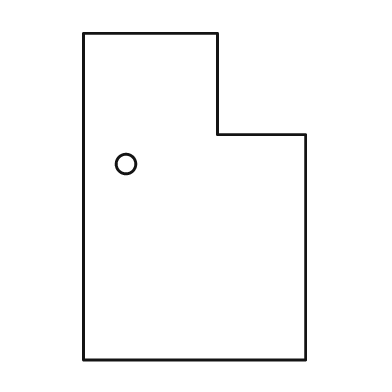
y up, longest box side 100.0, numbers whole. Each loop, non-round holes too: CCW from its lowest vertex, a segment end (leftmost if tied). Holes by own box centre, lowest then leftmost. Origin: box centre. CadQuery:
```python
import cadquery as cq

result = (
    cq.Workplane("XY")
    .moveTo(-34.0, -50.0)
    .lineTo(34.0, -50.0)
    .lineTo(34.0, 19.0)
    .lineTo(7.0, 19.0)
    .lineTo(7.0, 50.0)
    .lineTo(-34.0, 50.0)
    .close()
    .moveTo(-21.0, 10.0)
    .circle(3.0)
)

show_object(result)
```